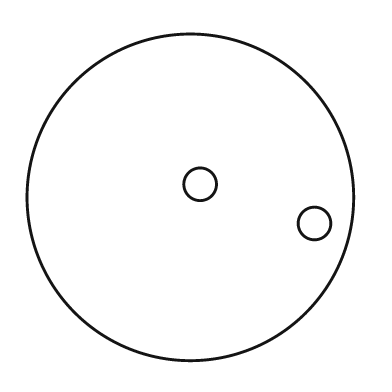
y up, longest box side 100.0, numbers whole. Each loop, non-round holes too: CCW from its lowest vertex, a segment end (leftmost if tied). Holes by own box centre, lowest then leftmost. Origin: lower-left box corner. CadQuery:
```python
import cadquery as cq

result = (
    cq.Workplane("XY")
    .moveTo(50.0, 50.0)
    .circle(50.0)
    .moveTo(88.0, 42.0)
    .circle(5.0)
    .moveTo(53.0, 54.0)
    .circle(5.0)
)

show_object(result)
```